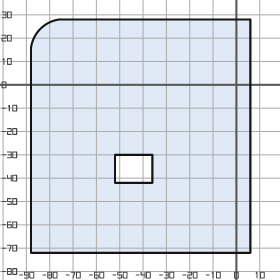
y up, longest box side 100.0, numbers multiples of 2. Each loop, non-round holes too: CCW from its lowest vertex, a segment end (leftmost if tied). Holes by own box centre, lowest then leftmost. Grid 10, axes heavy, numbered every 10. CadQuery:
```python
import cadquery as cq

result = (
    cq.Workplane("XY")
    .moveTo(-88.0, -72.0)
    .lineTo(6.0, -72.0)
    .lineTo(6.0, 28.0)
    .lineTo(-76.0, 28.0)
    .threePointArc((-84.0, 24.0), (-88.0, 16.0))
    .close()
    .moveTo(-52.0, -42.0)
    .lineTo(-36.0, -42.0)
    .lineTo(-36.0, -30.0)
    .lineTo(-52.0, -30.0)
    .close()
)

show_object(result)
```